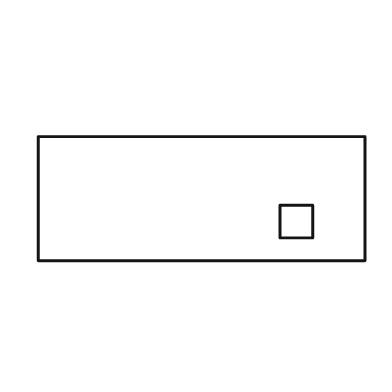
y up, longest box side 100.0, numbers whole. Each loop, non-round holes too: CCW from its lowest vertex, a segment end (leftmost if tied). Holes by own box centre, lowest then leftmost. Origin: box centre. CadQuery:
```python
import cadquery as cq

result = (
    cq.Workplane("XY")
    .moveTo(-50.0, -19.0)
    .lineTo(50.0, -19.0)
    .lineTo(50.0, 19.0)
    .lineTo(-50.0, 19.0)
    .close()
    .moveTo(24.0, -12.0)
    .lineTo(34.0, -12.0)
    .lineTo(34.0, -2.0)
    .lineTo(24.0, -2.0)
    .close()
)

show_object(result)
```